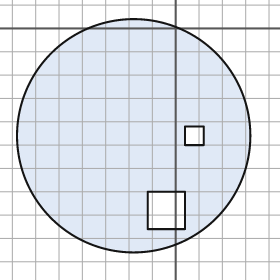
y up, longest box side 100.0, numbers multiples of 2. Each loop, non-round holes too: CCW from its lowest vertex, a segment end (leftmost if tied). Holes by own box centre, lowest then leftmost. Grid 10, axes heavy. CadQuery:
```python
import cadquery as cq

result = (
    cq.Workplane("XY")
    .moveTo(-18.0, -46.0)
    .circle(50.0)
    .moveTo(-12.0, -86.0)
    .lineTo(4.0, -86.0)
    .lineTo(4.0, -70.0)
    .lineTo(-12.0, -70.0)
    .close()
    .moveTo(4.0, -50.0)
    .lineTo(12.0, -50.0)
    .lineTo(12.0, -42.0)
    .lineTo(4.0, -42.0)
    .close()
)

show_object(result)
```